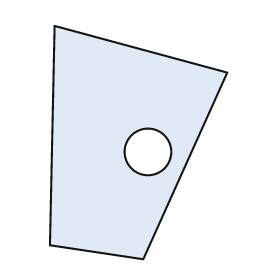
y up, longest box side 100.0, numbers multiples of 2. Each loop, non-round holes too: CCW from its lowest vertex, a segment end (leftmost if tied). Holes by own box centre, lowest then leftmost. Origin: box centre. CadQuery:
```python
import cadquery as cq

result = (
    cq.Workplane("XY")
    .moveTo(2.0, -50.0)
    .lineTo(38.0, 30.0)
    .lineTo(-36.0, 50.0)
    .lineTo(-38.0, -44.0)
    .close()
    .moveTo(4.0, -4.0)
    .circle(10.0)
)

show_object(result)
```